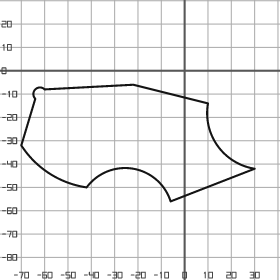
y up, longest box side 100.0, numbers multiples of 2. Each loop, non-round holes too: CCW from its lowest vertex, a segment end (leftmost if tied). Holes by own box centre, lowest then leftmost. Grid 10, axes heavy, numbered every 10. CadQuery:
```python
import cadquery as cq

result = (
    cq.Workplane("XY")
    .moveTo(-6.0, -56.0)
    .lineTo(30.0, -42.0)
    .threePointArc((14.0, -32.0), (10.0, -14.0))
    .lineTo(-22.0, -6.0)
    .lineTo(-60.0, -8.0)
    .threePointArc((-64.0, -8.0), (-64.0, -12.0))
    .lineTo(-70.0, -32.0)
    .threePointArc((-58.0, -44.0), (-42.0, -50.0))
    .threePointArc((-22.0, -42.0), (-6.0, -56.0))
    .close()
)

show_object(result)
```